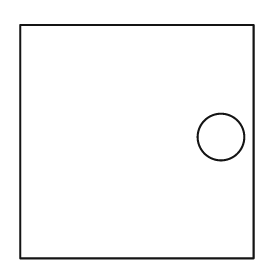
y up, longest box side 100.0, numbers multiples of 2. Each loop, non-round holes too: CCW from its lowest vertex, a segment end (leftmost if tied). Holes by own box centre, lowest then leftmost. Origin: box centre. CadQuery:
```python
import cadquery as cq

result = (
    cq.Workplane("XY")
    .moveTo(-50.0, -50.0)
    .lineTo(50.0, -50.0)
    .lineTo(50.0, 50.0)
    .lineTo(-50.0, 50.0)
    .close()
    .moveTo(36.0, 2.0)
    .circle(10.0)
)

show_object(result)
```